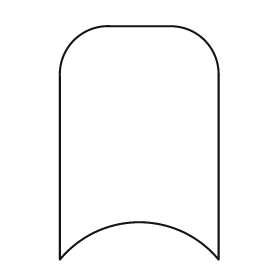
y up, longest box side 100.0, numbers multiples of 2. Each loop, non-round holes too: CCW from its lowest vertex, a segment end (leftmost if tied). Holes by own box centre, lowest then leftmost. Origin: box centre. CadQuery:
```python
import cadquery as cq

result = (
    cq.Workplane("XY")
    .moveTo(-34.0, -50.0)
    .threePointArc((0.0, -34.0), (34.0, -50.0))
    .lineTo(34.0, 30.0)
    .threePointArc((28.0, 44.0), (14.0, 50.0))
    .lineTo(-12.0, 50.0)
    .threePointArc((-28.0, 44.0), (-34.0, 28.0))
    .close()
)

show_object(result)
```